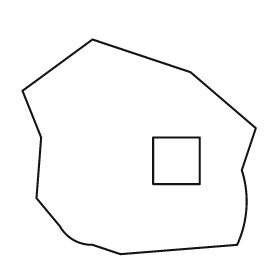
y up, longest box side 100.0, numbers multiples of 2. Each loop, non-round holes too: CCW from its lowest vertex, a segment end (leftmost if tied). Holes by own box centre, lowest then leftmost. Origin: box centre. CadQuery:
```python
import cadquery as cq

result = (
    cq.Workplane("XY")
    .moveTo(-8.0, -46.0)
    .lineTo(42.0, -42.0)
    .threePointArc((46.0, -26.0), (44.0, -10.0))
    .lineTo(50.0, 8.0)
    .lineTo(22.0, 32.0)
    .lineTo(-20.0, 46.0)
    .lineTo(-50.0, 24.0)
    .lineTo(-42.0, 4.0)
    .lineTo(-44.0, -22.0)
    .lineTo(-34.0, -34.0)
    .threePointArc((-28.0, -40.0), (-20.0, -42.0))
    .close()
    .moveTo(6.0, -16.0)
    .lineTo(26.0, -16.0)
    .lineTo(26.0, 4.0)
    .lineTo(6.0, 4.0)
    .close()
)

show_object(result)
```